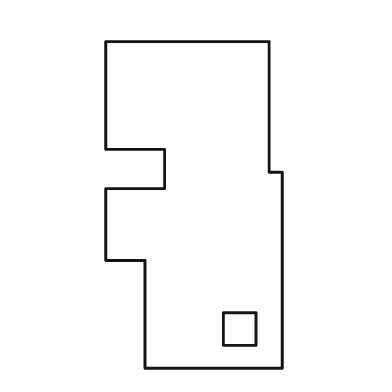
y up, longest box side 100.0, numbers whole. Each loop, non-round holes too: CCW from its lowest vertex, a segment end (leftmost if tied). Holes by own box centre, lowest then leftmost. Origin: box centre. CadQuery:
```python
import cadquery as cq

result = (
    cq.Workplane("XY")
    .moveTo(-15.0, -50.0)
    .lineTo(27.0, -50.0)
    .lineTo(27.0, 10.0)
    .lineTo(23.0, 10.0)
    .lineTo(23.0, 50.0)
    .lineTo(-27.0, 50.0)
    .lineTo(-27.0, 17.0)
    .lineTo(-9.0, 17.0)
    .lineTo(-9.0, 5.0)
    .lineTo(-27.0, 5.0)
    .lineTo(-27.0, -17.0)
    .lineTo(-15.0, -17.0)
    .close()
    .moveTo(9.0, -43.0)
    .lineTo(19.0, -43.0)
    .lineTo(19.0, -33.0)
    .lineTo(9.0, -33.0)
    .close()
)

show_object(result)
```